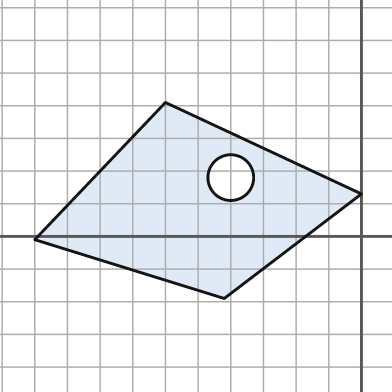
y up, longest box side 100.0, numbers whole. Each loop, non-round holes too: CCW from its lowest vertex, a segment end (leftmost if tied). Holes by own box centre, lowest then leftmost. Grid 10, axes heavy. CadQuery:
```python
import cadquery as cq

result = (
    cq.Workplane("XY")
    .moveTo(-42.0, -19.0)
    .lineTo(0.0, 13.0)
    .lineTo(-60.0, 41.0)
    .lineTo(-100.0, -1.0)
    .close()
    .moveTo(-40.0, 18.0)
    .circle(7.0)
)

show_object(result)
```